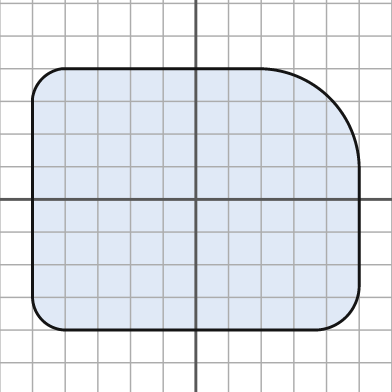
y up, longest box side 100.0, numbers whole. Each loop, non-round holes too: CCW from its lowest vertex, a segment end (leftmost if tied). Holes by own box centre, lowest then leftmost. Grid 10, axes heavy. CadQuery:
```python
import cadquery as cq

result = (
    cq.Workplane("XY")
    .moveTo(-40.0, -40.0)
    .lineTo(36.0, -40.0)
    .threePointArc((46.0, -36.0), (50.0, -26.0))
    .lineTo(50.0, 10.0)
    .threePointArc((41.0, 31.0), (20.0, 40.0))
    .lineTo(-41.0, 40.0)
    .threePointArc((-47.0, 37.0), (-50.0, 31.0))
    .lineTo(-50.0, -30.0)
    .threePointArc((-47.0, -37.0), (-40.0, -40.0))
    .close()
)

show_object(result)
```